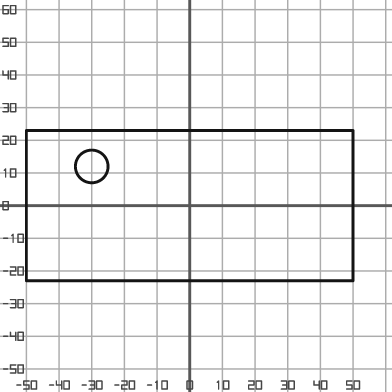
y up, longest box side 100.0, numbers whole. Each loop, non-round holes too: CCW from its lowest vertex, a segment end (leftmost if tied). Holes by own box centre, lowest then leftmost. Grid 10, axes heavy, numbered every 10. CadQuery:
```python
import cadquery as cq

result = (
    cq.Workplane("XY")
    .moveTo(-50.0, -23.0)
    .lineTo(50.0, -23.0)
    .lineTo(50.0, 23.0)
    .lineTo(-50.0, 23.0)
    .close()
    .moveTo(-30.0, 12.0)
    .circle(5.0)
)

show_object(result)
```